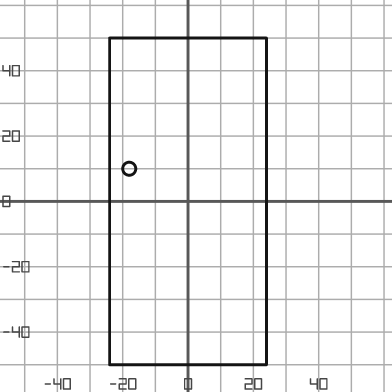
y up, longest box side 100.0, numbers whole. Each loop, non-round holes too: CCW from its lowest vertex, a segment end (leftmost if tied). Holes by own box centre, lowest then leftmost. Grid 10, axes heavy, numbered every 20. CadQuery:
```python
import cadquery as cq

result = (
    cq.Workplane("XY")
    .moveTo(-24.0, -50.0)
    .lineTo(24.0, -50.0)
    .lineTo(24.0, 50.0)
    .lineTo(-24.0, 50.0)
    .close()
    .moveTo(-18.0, 10.0)
    .circle(2.0)
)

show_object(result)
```